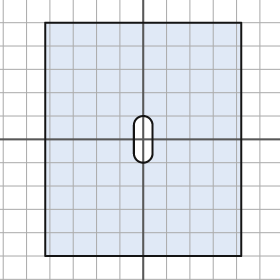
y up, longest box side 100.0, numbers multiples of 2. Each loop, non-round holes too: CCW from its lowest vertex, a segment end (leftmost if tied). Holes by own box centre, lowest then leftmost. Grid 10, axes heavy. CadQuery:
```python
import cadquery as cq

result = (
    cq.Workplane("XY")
    .moveTo(-42.0, -50.0)
    .lineTo(42.0, -50.0)
    .lineTo(42.0, 50.0)
    .lineTo(-42.0, 50.0)
    .close()
    .moveTo(-4.0, -6.0)
    .threePointArc((0.0, -10.0), (4.0, -6.0))
    .lineTo(4.0, 6.0)
    .threePointArc((0.0, 10.0), (-4.0, 6.0))
    .close()
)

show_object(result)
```